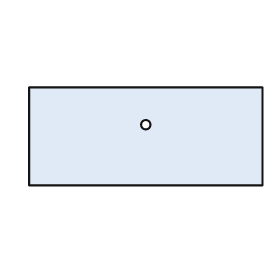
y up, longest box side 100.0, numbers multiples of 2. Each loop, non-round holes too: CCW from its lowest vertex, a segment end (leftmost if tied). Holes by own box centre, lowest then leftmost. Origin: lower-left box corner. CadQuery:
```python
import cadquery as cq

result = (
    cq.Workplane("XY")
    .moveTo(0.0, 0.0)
    .lineTo(100.0, 0.0)
    .lineTo(100.0, 42.0)
    .lineTo(0.0, 42.0)
    .close()
    .moveTo(50.0, 26.0)
    .circle(2.0)
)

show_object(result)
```